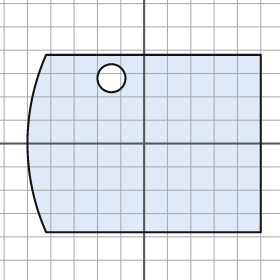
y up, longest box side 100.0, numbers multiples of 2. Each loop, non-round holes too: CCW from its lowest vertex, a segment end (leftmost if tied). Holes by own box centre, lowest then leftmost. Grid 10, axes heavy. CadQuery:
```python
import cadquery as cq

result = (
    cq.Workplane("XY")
    .moveTo(-42.0, -38.0)
    .lineTo(50.0, -38.0)
    .lineTo(50.0, 38.0)
    .lineTo(-42.0, 38.0)
    .threePointArc((-50.0, 0.0), (-42.0, -38.0))
    .close()
    .moveTo(-14.0, 28.0)
    .circle(6.0)
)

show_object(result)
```